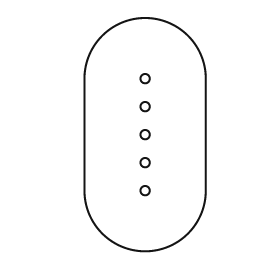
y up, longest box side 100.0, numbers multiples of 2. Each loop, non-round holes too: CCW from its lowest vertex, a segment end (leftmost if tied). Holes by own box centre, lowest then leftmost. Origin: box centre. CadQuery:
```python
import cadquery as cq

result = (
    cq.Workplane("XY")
    .moveTo(-26.0, -24.0)
    .threePointArc((0.0, -50.0), (26.0, -24.0))
    .lineTo(26.0, 24.0)
    .threePointArc((0.0, 50.0), (-26.0, 24.0))
    .close()
    .moveTo(0.0, -24.0)
    .circle(2.0)
    .moveTo(0.0, -12.0)
    .circle(2.0)
    .moveTo(0.0, 0.0)
    .circle(2.0)
    .moveTo(0.0, 12.0)
    .circle(2.0)
    .moveTo(0.0, 24.0)
    .circle(2.0)
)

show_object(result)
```